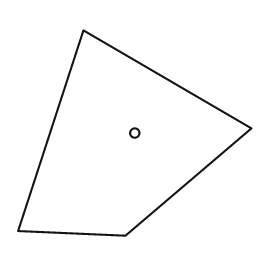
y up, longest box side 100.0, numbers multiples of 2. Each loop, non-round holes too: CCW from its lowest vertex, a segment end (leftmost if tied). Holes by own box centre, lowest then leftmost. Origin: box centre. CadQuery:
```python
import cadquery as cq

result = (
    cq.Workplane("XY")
    .moveTo(-4.0, -44.0)
    .lineTo(50.0, 2.0)
    .lineTo(-22.0, 44.0)
    .lineTo(-50.0, -42.0)
    .close()
    .moveTo(0.0, 0.0)
    .circle(2.0)
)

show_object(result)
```